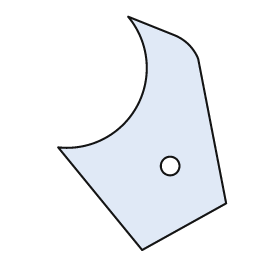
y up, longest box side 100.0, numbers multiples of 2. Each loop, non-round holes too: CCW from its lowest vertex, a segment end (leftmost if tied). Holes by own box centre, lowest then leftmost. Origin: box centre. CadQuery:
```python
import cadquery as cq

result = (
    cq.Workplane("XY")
    .moveTo(0.0, -50.0)
    .lineTo(36.0, -30.0)
    .lineTo(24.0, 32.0)
    .threePointArc((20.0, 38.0), (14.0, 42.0))
    .lineTo(-6.0, 50.0)
    .threePointArc((-2.0, 12.0), (-36.0, -6.0))
    .close()
    .moveTo(12.0, -14.0)
    .circle(4.0)
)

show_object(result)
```